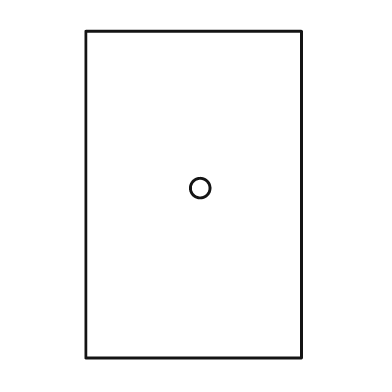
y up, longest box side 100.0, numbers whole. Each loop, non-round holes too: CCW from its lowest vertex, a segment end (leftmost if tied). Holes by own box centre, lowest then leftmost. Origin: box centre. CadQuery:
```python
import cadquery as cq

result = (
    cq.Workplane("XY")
    .moveTo(-33.0, -50.0)
    .lineTo(33.0, -50.0)
    .lineTo(33.0, 50.0)
    .lineTo(-33.0, 50.0)
    .close()
    .moveTo(2.0, 2.0)
    .circle(3.0)
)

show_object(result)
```